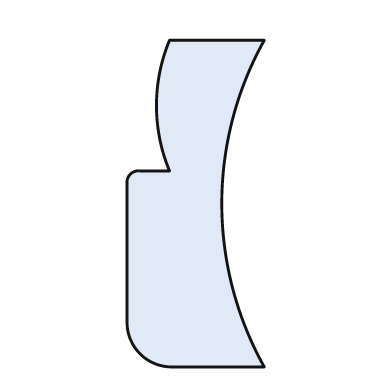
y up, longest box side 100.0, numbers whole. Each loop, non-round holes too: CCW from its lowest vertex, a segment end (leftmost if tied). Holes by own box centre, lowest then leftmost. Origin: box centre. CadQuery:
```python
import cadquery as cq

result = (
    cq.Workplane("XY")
    .moveTo(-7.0, -50.0)
    .lineTo(21.0, -50.0)
    .threePointArc((8.0, 0.0), (21.0, 50.0))
    .lineTo(-8.0, 50.0)
    .threePointArc((-12.0, 30.0), (-8.0, 10.0))
    .lineTo(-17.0, 10.0)
    .threePointArc((-20.0, 9.0), (-21.0, 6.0))
    .lineTo(-21.0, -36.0)
    .threePointArc((-17.0, -46.0), (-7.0, -50.0))
    .close()
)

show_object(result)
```